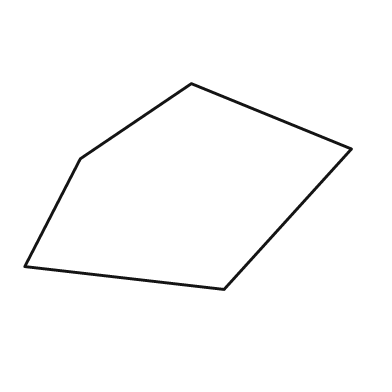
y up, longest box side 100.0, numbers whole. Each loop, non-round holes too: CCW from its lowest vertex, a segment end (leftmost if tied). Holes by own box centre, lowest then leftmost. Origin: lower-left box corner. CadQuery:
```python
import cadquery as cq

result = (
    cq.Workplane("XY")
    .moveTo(61.0, 0.0)
    .lineTo(100.0, 43.0)
    .lineTo(51.0, 63.0)
    .lineTo(17.0, 40.0)
    .lineTo(0.0, 7.0)
    .close()
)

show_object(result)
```